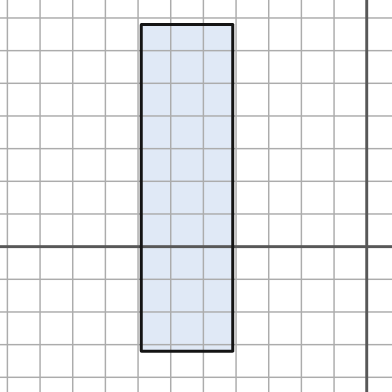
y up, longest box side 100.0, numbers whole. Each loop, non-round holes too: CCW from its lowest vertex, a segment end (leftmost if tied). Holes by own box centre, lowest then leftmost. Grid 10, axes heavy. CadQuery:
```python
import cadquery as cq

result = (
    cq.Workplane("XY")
    .moveTo(-69.0, -32.0)
    .lineTo(-41.0, -32.0)
    .lineTo(-41.0, 68.0)
    .lineTo(-69.0, 68.0)
    .close()
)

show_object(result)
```